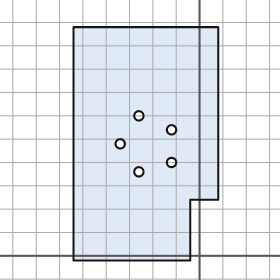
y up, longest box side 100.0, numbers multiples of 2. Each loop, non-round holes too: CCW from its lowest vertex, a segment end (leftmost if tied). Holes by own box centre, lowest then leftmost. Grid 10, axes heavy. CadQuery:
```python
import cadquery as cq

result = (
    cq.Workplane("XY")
    .moveTo(-54.0, -2.0)
    .lineTo(-4.0, -2.0)
    .lineTo(-4.0, 24.0)
    .lineTo(8.0, 24.0)
    .lineTo(8.0, 98.0)
    .lineTo(-54.0, 98.0)
    .close()
    .moveTo(-26.0, 36.0)
    .circle(2.0)
    .moveTo(-12.0, 40.0)
    .circle(2.0)
    .moveTo(-34.0, 48.0)
    .circle(2.0)
    .moveTo(-12.0, 54.0)
    .circle(2.0)
    .moveTo(-26.0, 60.0)
    .circle(2.0)
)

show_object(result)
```